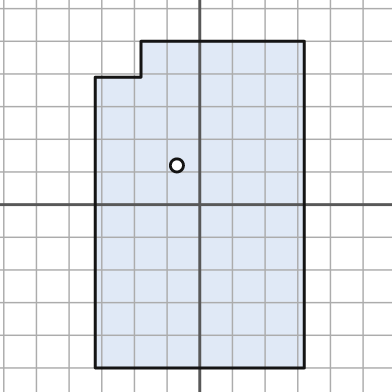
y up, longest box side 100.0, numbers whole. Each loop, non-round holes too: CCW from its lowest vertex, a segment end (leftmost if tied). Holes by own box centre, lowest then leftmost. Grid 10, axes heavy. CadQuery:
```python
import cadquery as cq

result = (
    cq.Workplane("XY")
    .moveTo(-32.0, -50.0)
    .lineTo(32.0, -50.0)
    .lineTo(32.0, 50.0)
    .lineTo(-18.0, 50.0)
    .lineTo(-18.0, 39.0)
    .lineTo(-32.0, 39.0)
    .close()
    .moveTo(-7.0, 12.0)
    .circle(2.0)
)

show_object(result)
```